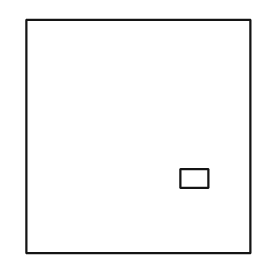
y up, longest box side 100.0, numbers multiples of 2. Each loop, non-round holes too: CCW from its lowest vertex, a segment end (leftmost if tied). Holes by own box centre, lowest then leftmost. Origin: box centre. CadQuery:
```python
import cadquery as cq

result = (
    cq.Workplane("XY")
    .moveTo(-48.0, -50.0)
    .lineTo(48.0, -50.0)
    .lineTo(48.0, 50.0)
    .lineTo(-48.0, 50.0)
    .close()
    .moveTo(18.0, -22.0)
    .lineTo(30.0, -22.0)
    .lineTo(30.0, -14.0)
    .lineTo(18.0, -14.0)
    .close()
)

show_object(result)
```